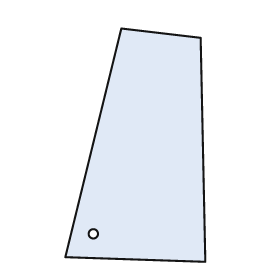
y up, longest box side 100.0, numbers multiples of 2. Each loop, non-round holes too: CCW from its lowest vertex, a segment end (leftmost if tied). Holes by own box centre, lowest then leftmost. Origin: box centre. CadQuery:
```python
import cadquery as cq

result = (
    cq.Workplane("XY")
    .moveTo(30.0, -50.0)
    .lineTo(28.0, 46.0)
    .lineTo(-6.0, 50.0)
    .lineTo(-30.0, -48.0)
    .close()
    .moveTo(-18.0, -38.0)
    .circle(2.0)
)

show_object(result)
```